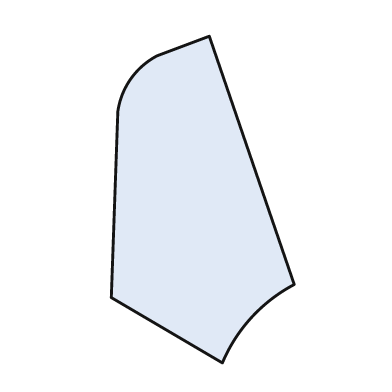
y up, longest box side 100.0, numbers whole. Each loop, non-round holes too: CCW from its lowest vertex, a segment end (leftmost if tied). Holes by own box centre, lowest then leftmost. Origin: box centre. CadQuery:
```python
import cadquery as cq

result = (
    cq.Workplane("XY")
    .moveTo(6.0, -50.0)
    .threePointArc((15.0, -36.0), (28.0, -26.0))
    .lineTo(2.0, 50.0)
    .lineTo(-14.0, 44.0)
    .threePointArc((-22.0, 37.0), (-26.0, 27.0))
    .lineTo(-28.0, -30.0)
    .close()
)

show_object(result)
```